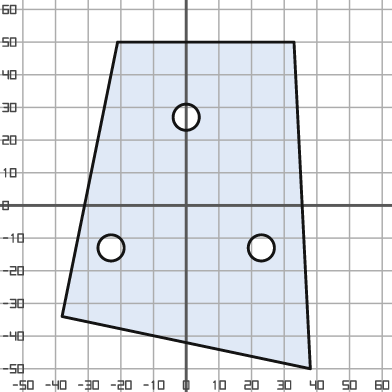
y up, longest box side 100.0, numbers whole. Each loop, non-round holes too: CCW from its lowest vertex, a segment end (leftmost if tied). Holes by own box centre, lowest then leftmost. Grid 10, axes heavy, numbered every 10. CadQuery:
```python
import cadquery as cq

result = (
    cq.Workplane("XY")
    .moveTo(38.0, -50.0)
    .lineTo(33.0, 50.0)
    .lineTo(-21.0, 50.0)
    .lineTo(-38.0, -34.0)
    .close()
    .moveTo(-23.0, -13.0)
    .circle(4.0)
    .moveTo(23.0, -13.0)
    .circle(4.0)
    .moveTo(0.0, 27.0)
    .circle(4.0)
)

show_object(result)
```